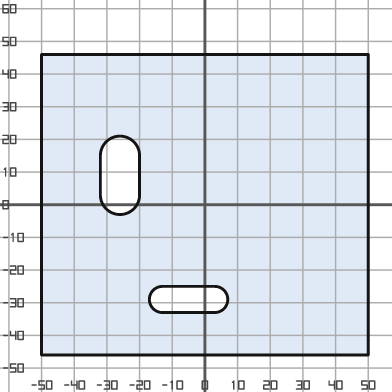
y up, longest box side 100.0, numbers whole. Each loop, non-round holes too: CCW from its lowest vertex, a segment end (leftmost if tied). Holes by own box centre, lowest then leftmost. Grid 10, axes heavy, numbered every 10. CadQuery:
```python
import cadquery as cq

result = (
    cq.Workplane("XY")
    .moveTo(-50.0, -46.0)
    .lineTo(50.0, -46.0)
    .lineTo(50.0, 46.0)
    .lineTo(-50.0, 46.0)
    .close()
    .moveTo(-13.0, -33.0)
    .lineTo(3.0, -33.0)
    .threePointArc((7.0, -29.0), (3.0, -25.0))
    .lineTo(-13.0, -25.0)
    .threePointArc((-17.0, -29.0), (-13.0, -33.0))
    .close()
    .moveTo(-32.0, 3.0)
    .threePointArc((-26.0, -3.0), (-20.0, 3.0))
    .lineTo(-20.0, 15.0)
    .threePointArc((-26.0, 21.0), (-32.0, 15.0))
    .close()
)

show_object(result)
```